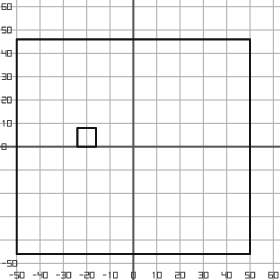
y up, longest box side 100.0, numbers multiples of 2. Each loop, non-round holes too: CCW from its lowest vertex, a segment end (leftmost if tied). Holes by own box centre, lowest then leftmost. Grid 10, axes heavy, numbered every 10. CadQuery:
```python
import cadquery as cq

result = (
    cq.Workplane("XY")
    .moveTo(-50.0, -46.0)
    .lineTo(50.0, -46.0)
    .lineTo(50.0, 46.0)
    .lineTo(-50.0, 46.0)
    .close()
    .moveTo(-24.0, 0.0)
    .lineTo(-16.0, 0.0)
    .lineTo(-16.0, 8.0)
    .lineTo(-24.0, 8.0)
    .close()
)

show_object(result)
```